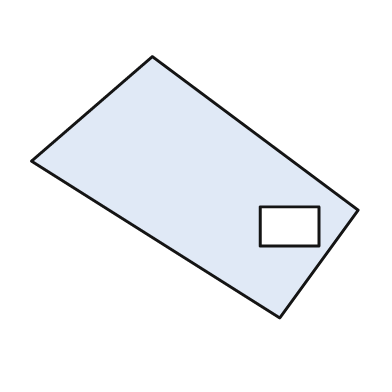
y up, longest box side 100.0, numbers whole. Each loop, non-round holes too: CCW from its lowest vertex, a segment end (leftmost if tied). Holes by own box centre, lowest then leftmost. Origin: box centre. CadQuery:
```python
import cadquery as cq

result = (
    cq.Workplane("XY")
    .moveTo(26.0, -40.0)
    .lineTo(50.0, -7.0)
    .lineTo(-13.0, 40.0)
    .lineTo(-50.0, 8.0)
    .close()
    .moveTo(20.0, -18.0)
    .lineTo(38.0, -18.0)
    .lineTo(38.0, -6.0)
    .lineTo(20.0, -6.0)
    .close()
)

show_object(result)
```